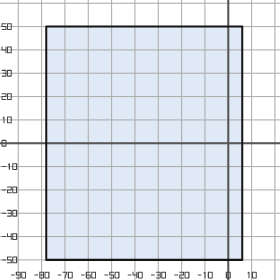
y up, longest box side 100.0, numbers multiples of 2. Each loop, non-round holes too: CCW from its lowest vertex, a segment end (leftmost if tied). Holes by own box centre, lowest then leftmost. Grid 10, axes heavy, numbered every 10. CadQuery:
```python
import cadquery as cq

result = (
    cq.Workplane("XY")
    .moveTo(-78.0, -50.0)
    .lineTo(6.0, -50.0)
    .lineTo(6.0, 50.0)
    .lineTo(-78.0, 50.0)
    .close()
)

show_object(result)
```